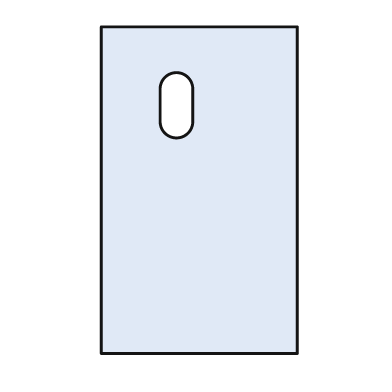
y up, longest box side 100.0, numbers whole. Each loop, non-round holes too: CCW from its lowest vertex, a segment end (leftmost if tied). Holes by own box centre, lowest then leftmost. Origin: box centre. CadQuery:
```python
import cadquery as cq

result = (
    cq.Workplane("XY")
    .moveTo(-30.0, -50.0)
    .lineTo(30.0, -50.0)
    .lineTo(30.0, 50.0)
    .lineTo(-30.0, 50.0)
    .close()
    .moveTo(-12.0, 21.0)
    .threePointArc((-7.0, 16.0), (-2.0, 21.0))
    .lineTo(-2.0, 31.0)
    .threePointArc((-7.0, 36.0), (-12.0, 31.0))
    .close()
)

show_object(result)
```